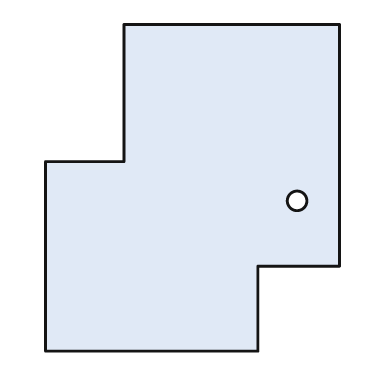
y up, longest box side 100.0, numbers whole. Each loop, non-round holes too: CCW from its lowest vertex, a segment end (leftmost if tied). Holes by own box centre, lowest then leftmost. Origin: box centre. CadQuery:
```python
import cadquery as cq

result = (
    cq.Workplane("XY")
    .moveTo(-45.0, -50.0)
    .lineTo(20.0, -50.0)
    .lineTo(20.0, -24.0)
    .lineTo(45.0, -24.0)
    .lineTo(45.0, 50.0)
    .lineTo(-21.0, 50.0)
    .lineTo(-21.0, 8.0)
    .lineTo(-45.0, 8.0)
    .close()
    .moveTo(32.0, -4.0)
    .circle(3.0)
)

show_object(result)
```